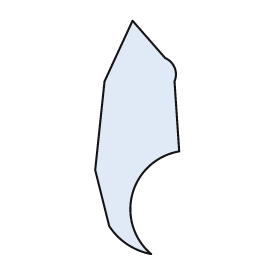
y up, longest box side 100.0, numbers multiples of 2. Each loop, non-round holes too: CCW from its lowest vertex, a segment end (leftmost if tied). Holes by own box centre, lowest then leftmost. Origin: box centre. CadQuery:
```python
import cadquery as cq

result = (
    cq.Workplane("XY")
    .moveTo(6.0, -50.0)
    .threePointArc((-2.0, -24.0), (18.0, -6.0))
    .lineTo(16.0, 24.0)
    .threePointArc((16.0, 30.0), (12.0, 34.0))
    .lineTo(-2.0, 50.0)
    .lineTo(-14.0, 24.0)
    .lineTo(-18.0, -14.0)
    .lineTo(-12.0, -38.0)
    .threePointArc((-4.0, -46.0), (6.0, -50.0))
    .close()
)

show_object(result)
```